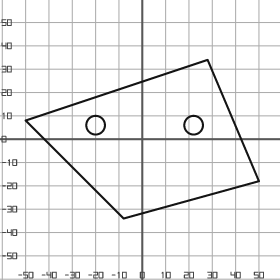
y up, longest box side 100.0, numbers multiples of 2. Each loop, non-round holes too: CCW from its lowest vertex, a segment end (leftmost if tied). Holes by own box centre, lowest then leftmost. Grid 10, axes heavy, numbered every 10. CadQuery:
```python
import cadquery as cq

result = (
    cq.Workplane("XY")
    .moveTo(-8.0, -34.0)
    .lineTo(50.0, -18.0)
    .lineTo(28.0, 34.0)
    .lineTo(-50.0, 8.0)
    .close()
    .moveTo(-20.0, 6.0)
    .circle(4.0)
    .moveTo(22.0, 6.0)
    .circle(4.0)
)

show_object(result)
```